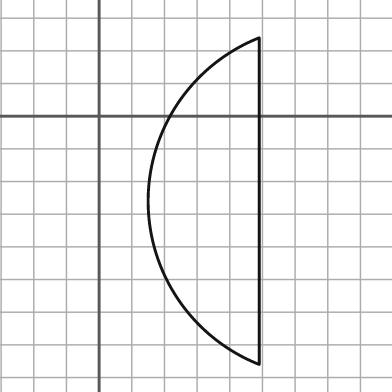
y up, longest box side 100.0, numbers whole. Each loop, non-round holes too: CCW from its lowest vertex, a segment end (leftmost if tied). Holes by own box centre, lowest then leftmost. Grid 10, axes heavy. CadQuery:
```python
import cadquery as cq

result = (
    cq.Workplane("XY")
    .moveTo(49.0, -76.0)
    .lineTo(49.0, 24.0)
    .threePointArc((15.0, -26.0), (49.0, -76.0))
    .close()
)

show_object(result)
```